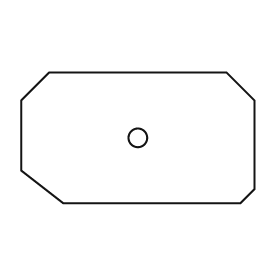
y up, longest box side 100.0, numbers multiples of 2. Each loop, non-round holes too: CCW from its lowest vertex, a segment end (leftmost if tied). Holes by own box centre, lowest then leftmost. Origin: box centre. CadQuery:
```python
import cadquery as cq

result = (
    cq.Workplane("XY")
    .moveTo(-32.0, -28.0)
    .lineTo(44.0, -28.0)
    .lineTo(50.0, -22.0)
    .lineTo(50.0, 16.0)
    .lineTo(38.0, 28.0)
    .lineTo(-38.0, 28.0)
    .lineTo(-50.0, 16.0)
    .lineTo(-50.0, -14.0)
    .close()
    .moveTo(0.0, 0.0)
    .circle(4.0)
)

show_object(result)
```